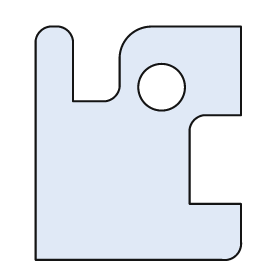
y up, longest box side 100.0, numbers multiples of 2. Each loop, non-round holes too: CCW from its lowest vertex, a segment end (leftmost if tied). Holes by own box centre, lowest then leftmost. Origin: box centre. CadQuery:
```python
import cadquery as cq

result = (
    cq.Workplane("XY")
    .moveTo(-44.0, -50.0)
    .lineTo(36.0, -50.0)
    .threePointArc((42.0, -48.0), (44.0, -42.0))
    .lineTo(44.0, -26.0)
    .lineTo(22.0, -26.0)
    .lineTo(22.0, 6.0)
    .threePointArc((24.0, 10.0), (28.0, 12.0))
    .lineTo(44.0, 12.0)
    .lineTo(44.0, 50.0)
    .lineTo(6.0, 50.0)
    .threePointArc((-4.0, 46.0), (-8.0, 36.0))
    .lineTo(-8.0, 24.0)
    .threePointArc((-10.0, 20.0), (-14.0, 18.0))
    .lineTo(-28.0, 18.0)
    .lineTo(-28.0, 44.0)
    .threePointArc((-30.0, 48.0), (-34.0, 50.0))
    .lineTo(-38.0, 50.0)
    .threePointArc((-42.0, 48.0), (-44.0, 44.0))
    .close()
    .moveTo(10.0, 24.0)
    .circle(10.0)
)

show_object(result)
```